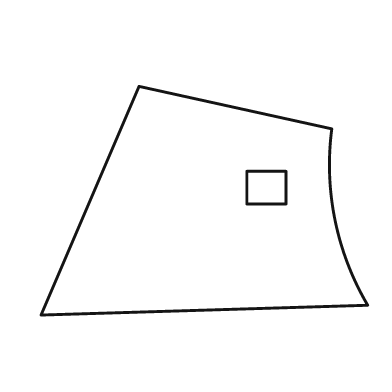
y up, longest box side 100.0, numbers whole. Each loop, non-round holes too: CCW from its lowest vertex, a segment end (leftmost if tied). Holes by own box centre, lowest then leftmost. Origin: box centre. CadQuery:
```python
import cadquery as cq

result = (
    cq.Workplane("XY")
    .moveTo(-50.0, -35.0)
    .lineTo(50.0, -32.0)
    .threePointArc((40.0, -6.0), (39.0, 22.0))
    .lineTo(-20.0, 35.0)
    .close()
    .moveTo(13.0, -1.0)
    .lineTo(25.0, -1.0)
    .lineTo(25.0, 9.0)
    .lineTo(13.0, 9.0)
    .close()
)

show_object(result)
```